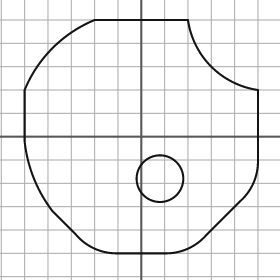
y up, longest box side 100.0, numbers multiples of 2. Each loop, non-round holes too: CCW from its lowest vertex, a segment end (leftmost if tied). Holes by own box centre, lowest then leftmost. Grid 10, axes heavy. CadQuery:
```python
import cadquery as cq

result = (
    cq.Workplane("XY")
    .moveTo(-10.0, -50.0)
    .lineTo(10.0, -50.0)
    .threePointArc((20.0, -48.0), (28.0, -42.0))
    .lineTo(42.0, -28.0)
    .threePointArc((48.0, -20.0), (50.0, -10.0))
    .lineTo(50.0, 20.0)
    .threePointArc((30.0, 30.0), (20.0, 50.0))
    .lineTo(-20.0, 50.0)
    .threePointArc((-38.0, 38.0), (-50.0, 20.0))
    .lineTo(-50.0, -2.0)
    .threePointArc((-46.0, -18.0), (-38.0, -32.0))
    .lineTo(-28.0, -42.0)
    .threePointArc((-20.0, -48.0), (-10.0, -50.0))
    .close()
    .moveTo(8.0, -18.0)
    .circle(10.0)
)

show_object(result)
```